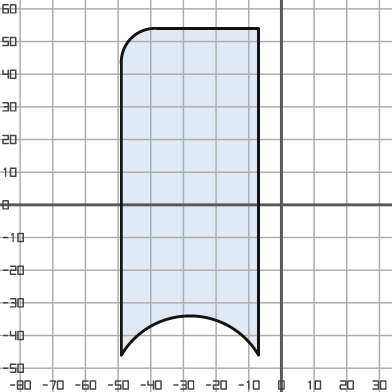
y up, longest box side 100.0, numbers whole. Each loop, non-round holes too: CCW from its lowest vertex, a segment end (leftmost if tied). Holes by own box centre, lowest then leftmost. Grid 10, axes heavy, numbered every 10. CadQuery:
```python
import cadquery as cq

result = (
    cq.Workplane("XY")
    .moveTo(-49.0, -46.0)
    .threePointArc((-28.0, -34.0), (-7.0, -46.0))
    .lineTo(-7.0, 54.0)
    .lineTo(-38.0, 54.0)
    .threePointArc((-46.0, 51.0), (-49.0, 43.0))
    .close()
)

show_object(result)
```